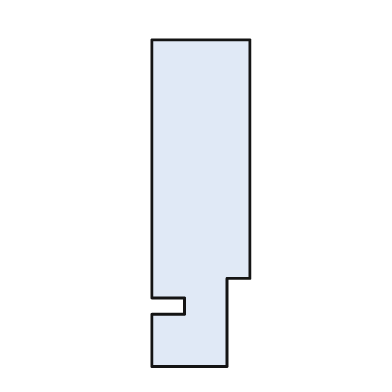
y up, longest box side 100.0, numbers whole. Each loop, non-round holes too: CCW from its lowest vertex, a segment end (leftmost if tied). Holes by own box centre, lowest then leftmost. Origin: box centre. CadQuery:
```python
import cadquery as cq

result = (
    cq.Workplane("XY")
    .moveTo(-15.0, -50.0)
    .lineTo(8.0, -50.0)
    .lineTo(8.0, -23.0)
    .lineTo(15.0, -23.0)
    .lineTo(15.0, 50.0)
    .lineTo(-15.0, 50.0)
    .lineTo(-15.0, -29.0)
    .lineTo(-5.0, -29.0)
    .lineTo(-5.0, -34.0)
    .lineTo(-15.0, -34.0)
    .close()
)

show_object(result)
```